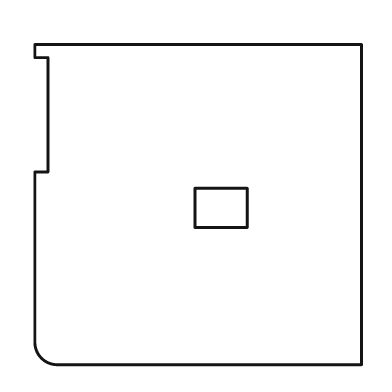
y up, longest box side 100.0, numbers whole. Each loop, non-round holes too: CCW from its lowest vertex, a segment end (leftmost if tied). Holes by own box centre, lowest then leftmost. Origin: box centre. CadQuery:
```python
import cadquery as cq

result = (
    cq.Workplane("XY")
    .moveTo(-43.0, -49.0)
    .lineTo(50.0, -49.0)
    .lineTo(50.0, 49.0)
    .lineTo(-50.0, 49.0)
    .lineTo(-50.0, 45.0)
    .lineTo(-46.0, 45.0)
    .lineTo(-46.0, 10.0)
    .lineTo(-50.0, 10.0)
    .lineTo(-50.0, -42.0)
    .threePointArc((-48.0, -47.0), (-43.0, -49.0))
    .close()
    .moveTo(-1.0, -7.0)
    .lineTo(15.0, -7.0)
    .lineTo(15.0, 5.0)
    .lineTo(-1.0, 5.0)
    .close()
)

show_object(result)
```